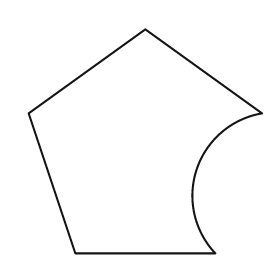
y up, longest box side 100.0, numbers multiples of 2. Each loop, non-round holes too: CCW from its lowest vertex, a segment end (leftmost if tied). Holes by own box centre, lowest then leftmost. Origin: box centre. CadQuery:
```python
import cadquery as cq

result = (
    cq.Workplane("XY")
    .moveTo(-30.0, -48.0)
    .lineTo(30.0, -48.0)
    .threePointArc((22.0, -12.0), (50.0, 12.0))
    .lineTo(0.0, 48.0)
    .lineTo(-50.0, 12.0)
    .close()
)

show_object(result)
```